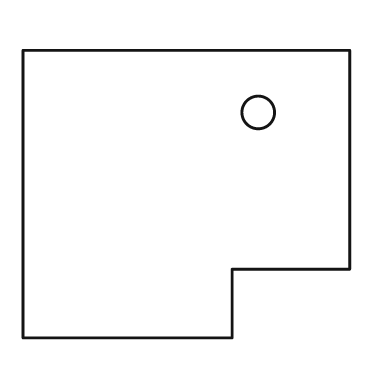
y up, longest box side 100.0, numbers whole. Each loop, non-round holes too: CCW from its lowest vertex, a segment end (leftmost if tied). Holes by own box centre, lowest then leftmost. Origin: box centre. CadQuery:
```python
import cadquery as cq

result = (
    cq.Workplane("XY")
    .moveTo(-50.0, -44.0)
    .lineTo(14.0, -44.0)
    .lineTo(14.0, -23.0)
    .lineTo(50.0, -23.0)
    .lineTo(50.0, 44.0)
    .lineTo(-50.0, 44.0)
    .close()
    .moveTo(22.0, 25.0)
    .circle(5.0)
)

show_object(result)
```